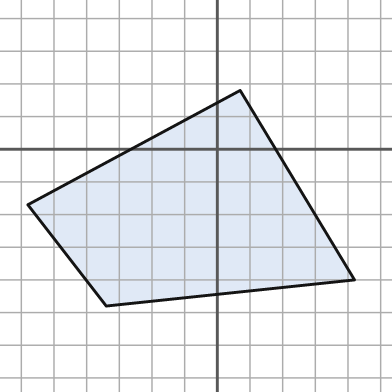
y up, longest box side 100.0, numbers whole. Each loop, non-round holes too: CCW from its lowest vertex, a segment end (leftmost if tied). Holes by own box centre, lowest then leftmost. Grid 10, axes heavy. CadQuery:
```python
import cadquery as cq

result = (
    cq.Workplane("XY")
    .moveTo(-34.0, -48.0)
    .lineTo(42.0, -40.0)
    .lineTo(7.0, 18.0)
    .lineTo(-58.0, -17.0)
    .close()
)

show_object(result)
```